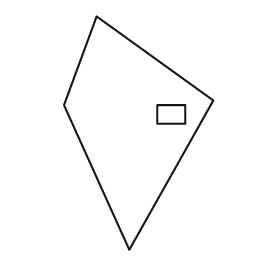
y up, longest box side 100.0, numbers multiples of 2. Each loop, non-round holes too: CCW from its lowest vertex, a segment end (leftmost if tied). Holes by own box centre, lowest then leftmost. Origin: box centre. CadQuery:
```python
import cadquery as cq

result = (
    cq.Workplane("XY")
    .moveTo(-4.0, -50.0)
    .lineTo(32.0, 14.0)
    .lineTo(-18.0, 50.0)
    .lineTo(-32.0, 12.0)
    .close()
    .moveTo(8.0, 4.0)
    .lineTo(20.0, 4.0)
    .lineTo(20.0, 12.0)
    .lineTo(8.0, 12.0)
    .close()
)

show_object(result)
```